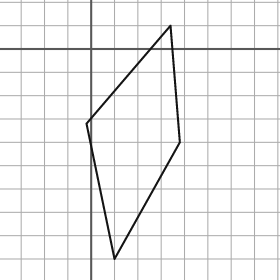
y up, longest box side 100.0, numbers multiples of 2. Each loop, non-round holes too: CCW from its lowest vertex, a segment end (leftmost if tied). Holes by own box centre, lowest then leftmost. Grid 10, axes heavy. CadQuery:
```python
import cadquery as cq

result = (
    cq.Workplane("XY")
    .moveTo(10.0, -90.0)
    .lineTo(38.0, -40.0)
    .lineTo(34.0, 10.0)
    .lineTo(-2.0, -32.0)
    .close()
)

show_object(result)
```